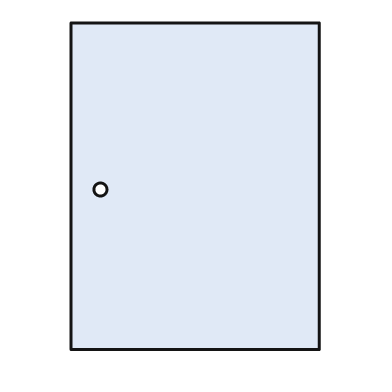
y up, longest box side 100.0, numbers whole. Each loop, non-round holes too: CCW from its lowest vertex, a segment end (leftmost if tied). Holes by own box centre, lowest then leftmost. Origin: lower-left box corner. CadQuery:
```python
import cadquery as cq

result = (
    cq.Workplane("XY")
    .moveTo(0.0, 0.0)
    .lineTo(76.0, 0.0)
    .lineTo(76.0, 100.0)
    .lineTo(0.0, 100.0)
    .close()
    .moveTo(9.0, 49.0)
    .circle(2.0)
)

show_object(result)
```